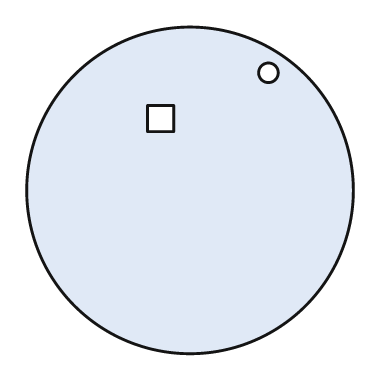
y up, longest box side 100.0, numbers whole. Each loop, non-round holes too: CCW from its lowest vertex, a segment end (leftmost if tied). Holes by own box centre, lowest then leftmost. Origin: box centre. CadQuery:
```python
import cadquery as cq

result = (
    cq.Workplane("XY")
    .moveTo(0.0, 0.0)
    .circle(50.0)
    .moveTo(-13.0, 18.0)
    .lineTo(-5.0, 18.0)
    .lineTo(-5.0, 26.0)
    .lineTo(-13.0, 26.0)
    .close()
    .moveTo(24.0, 36.0)
    .circle(3.0)
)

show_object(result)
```